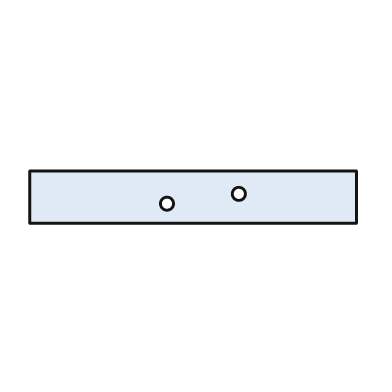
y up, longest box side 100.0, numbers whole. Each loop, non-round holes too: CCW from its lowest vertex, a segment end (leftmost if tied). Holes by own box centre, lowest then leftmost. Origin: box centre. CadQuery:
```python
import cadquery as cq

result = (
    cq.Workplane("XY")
    .moveTo(-50.0, -8.0)
    .lineTo(50.0, -8.0)
    .lineTo(50.0, 8.0)
    .lineTo(-50.0, 8.0)
    .close()
    .moveTo(-8.0, -2.0)
    .circle(2.0)
    .moveTo(14.0, 1.0)
    .circle(2.0)
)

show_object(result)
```